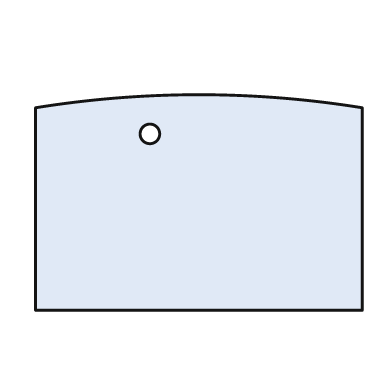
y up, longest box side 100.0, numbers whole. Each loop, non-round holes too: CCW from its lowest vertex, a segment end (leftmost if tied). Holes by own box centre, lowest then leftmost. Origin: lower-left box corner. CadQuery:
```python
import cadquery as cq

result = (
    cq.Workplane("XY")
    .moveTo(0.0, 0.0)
    .lineTo(100.0, 0.0)
    .lineTo(100.0, 62.0)
    .threePointArc((50.0, 66.0), (0.0, 62.0))
    .close()
    .moveTo(35.0, 54.0)
    .circle(3.0)
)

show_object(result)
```